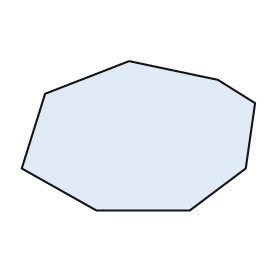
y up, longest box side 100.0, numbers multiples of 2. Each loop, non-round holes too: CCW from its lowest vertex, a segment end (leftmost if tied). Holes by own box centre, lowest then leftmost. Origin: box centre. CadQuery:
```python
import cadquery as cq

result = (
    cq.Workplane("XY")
    .moveTo(-18.0, -32.0)
    .lineTo(22.0, -32.0)
    .lineTo(46.0, -14.0)
    .lineTo(50.0, 14.0)
    .lineTo(34.0, 24.0)
    .lineTo(-4.0, 32.0)
    .lineTo(-40.0, 18.0)
    .lineTo(-50.0, -14.0)
    .close()
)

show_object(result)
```